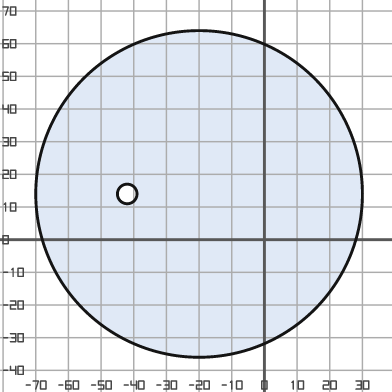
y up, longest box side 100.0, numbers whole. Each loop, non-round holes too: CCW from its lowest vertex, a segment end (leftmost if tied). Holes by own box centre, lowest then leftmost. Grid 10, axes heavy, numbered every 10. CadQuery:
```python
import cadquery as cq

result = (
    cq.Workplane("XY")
    .moveTo(-20.0, 14.0)
    .circle(50.0)
    .moveTo(-42.0, 14.0)
    .circle(3.0)
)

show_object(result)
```